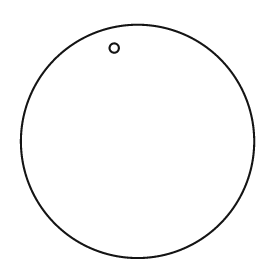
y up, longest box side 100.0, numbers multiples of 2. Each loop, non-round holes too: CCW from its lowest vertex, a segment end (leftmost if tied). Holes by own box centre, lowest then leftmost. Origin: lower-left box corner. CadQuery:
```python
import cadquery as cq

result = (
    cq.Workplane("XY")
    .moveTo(50.0, 50.0)
    .circle(50.0)
    .moveTo(40.0, 90.0)
    .circle(2.0)
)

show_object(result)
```